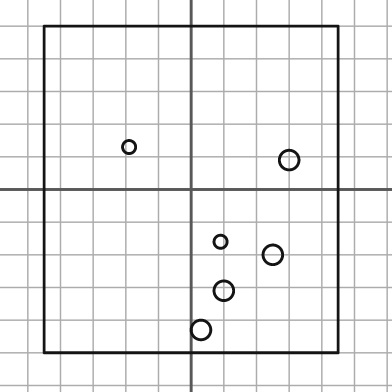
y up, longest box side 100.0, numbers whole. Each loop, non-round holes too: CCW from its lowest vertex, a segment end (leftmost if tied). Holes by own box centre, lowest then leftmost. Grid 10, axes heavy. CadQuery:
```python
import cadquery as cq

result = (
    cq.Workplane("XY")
    .moveTo(-45.0, -50.0)
    .lineTo(45.0, -50.0)
    .lineTo(45.0, 50.0)
    .lineTo(-45.0, 50.0)
    .close()
    .moveTo(3.0, -43.0)
    .circle(3.0)
    .moveTo(10.0, -31.0)
    .circle(3.0)
    .moveTo(25.0, -20.0)
    .circle(3.0)
    .moveTo(9.0, -16.0)
    .circle(2.0)
    .moveTo(30.0, 9.0)
    .circle(3.0)
    .moveTo(-19.0, 13.0)
    .circle(2.0)
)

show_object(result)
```